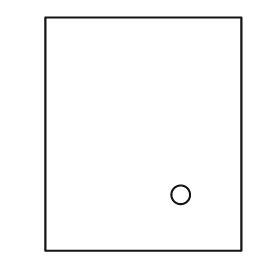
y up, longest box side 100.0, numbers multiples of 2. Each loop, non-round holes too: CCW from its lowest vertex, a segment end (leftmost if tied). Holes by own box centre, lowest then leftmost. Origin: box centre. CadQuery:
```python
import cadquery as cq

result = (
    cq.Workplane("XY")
    .moveTo(-42.0, -50.0)
    .lineTo(42.0, -50.0)
    .lineTo(42.0, 50.0)
    .lineTo(-42.0, 50.0)
    .close()
    .moveTo(16.0, -26.0)
    .circle(4.0)
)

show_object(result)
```